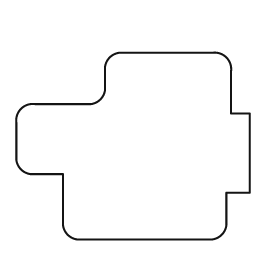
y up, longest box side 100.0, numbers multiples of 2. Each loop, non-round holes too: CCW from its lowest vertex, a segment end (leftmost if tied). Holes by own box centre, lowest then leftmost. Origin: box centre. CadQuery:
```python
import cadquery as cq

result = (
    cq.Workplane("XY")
    .moveTo(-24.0, -40.0)
    .lineTo(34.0, -40.0)
    .threePointArc((38.0, -38.0), (40.0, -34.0))
    .lineTo(40.0, -20.0)
    .lineTo(50.0, -20.0)
    .lineTo(50.0, 14.0)
    .lineTo(42.0, 14.0)
    .lineTo(42.0, 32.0)
    .threePointArc((40.0, 38.0), (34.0, 40.0))
    .lineTo(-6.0, 40.0)
    .threePointArc((-10.0, 38.0), (-12.0, 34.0))
    .lineTo(-12.0, 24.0)
    .threePointArc((-14.0, 20.0), (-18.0, 18.0))
    .lineTo(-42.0, 18.0)
    .threePointArc((-48.0, 16.0), (-50.0, 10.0))
    .lineTo(-50.0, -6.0)
    .threePointArc((-48.0, -10.0), (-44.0, -12.0))
    .lineTo(-30.0, -12.0)
    .lineTo(-30.0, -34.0)
    .threePointArc((-28.0, -38.0), (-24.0, -40.0))
    .close()
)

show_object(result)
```